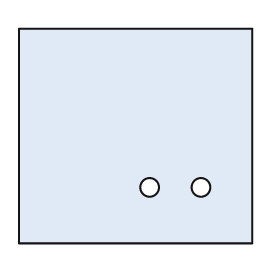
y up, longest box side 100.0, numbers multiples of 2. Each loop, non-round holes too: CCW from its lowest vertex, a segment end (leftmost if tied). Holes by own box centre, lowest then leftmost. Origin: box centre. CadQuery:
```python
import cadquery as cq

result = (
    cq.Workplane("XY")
    .moveTo(-50.0, -46.0)
    .lineTo(50.0, -46.0)
    .lineTo(50.0, 46.0)
    .lineTo(-50.0, 46.0)
    .close()
    .moveTo(6.0, -22.0)
    .circle(4.0)
    .moveTo(28.0, -22.0)
    .circle(4.0)
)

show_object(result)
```